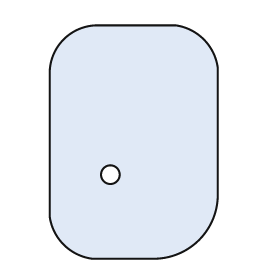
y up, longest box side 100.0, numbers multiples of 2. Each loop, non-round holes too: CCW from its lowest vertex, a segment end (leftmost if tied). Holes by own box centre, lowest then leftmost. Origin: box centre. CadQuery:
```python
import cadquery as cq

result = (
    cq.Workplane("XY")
    .moveTo(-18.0, -50.0)
    .lineTo(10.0, -50.0)
    .threePointArc((28.0, -42.0), (36.0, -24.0))
    .lineTo(36.0, 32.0)
    .threePointArc((30.0, 44.0), (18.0, 50.0))
    .lineTo(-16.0, 50.0)
    .threePointArc((-30.0, 44.0), (-36.0, 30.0))
    .lineTo(-36.0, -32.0)
    .threePointArc((-30.0, -44.0), (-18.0, -50.0))
    .close()
    .moveTo(-10.0, -14.0)
    .circle(4.0)
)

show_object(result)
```